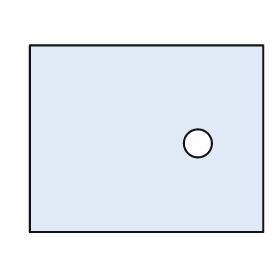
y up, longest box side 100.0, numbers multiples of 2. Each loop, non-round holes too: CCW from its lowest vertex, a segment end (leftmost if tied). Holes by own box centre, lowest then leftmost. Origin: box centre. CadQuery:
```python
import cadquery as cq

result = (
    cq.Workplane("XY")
    .moveTo(-50.0, -40.0)
    .lineTo(50.0, -40.0)
    .lineTo(50.0, 40.0)
    .lineTo(-50.0, 40.0)
    .close()
    .moveTo(22.0, -2.0)
    .circle(6.0)
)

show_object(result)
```